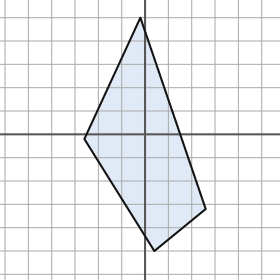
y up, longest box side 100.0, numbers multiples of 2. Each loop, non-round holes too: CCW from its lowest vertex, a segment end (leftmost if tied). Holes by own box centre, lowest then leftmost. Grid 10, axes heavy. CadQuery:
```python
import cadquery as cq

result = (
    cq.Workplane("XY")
    .moveTo(4.0, -50.0)
    .lineTo(26.0, -32.0)
    .lineTo(-2.0, 50.0)
    .lineTo(-26.0, -2.0)
    .close()
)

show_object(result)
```